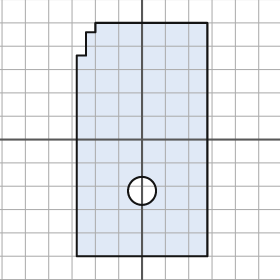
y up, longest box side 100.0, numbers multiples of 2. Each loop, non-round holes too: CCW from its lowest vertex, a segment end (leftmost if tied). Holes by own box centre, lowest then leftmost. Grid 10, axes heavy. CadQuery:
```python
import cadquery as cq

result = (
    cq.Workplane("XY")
    .moveTo(-28.0, -50.0)
    .lineTo(28.0, -50.0)
    .lineTo(28.0, 50.0)
    .lineTo(-20.0, 50.0)
    .lineTo(-20.0, 46.0)
    .lineTo(-24.0, 46.0)
    .lineTo(-24.0, 36.0)
    .lineTo(-28.0, 36.0)
    .close()
    .moveTo(0.0, -22.0)
    .circle(6.0)
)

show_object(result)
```